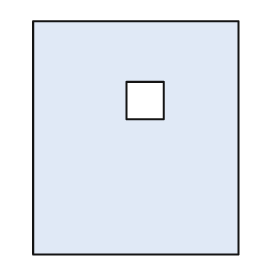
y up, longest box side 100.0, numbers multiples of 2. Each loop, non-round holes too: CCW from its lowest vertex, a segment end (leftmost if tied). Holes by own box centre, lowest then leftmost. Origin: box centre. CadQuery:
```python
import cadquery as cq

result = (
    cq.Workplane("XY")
    .moveTo(-44.0, -50.0)
    .lineTo(44.0, -50.0)
    .lineTo(44.0, 50.0)
    .lineTo(-44.0, 50.0)
    .close()
    .moveTo(-4.0, 8.0)
    .lineTo(12.0, 8.0)
    .lineTo(12.0, 24.0)
    .lineTo(-4.0, 24.0)
    .close()
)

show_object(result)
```